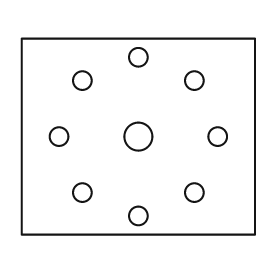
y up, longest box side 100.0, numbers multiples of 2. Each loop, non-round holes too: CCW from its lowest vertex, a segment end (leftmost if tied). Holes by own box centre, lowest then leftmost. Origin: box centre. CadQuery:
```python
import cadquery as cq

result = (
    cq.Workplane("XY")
    .moveTo(-50.0, -42.0)
    .lineTo(50.0, -42.0)
    .lineTo(50.0, 42.0)
    .lineTo(-50.0, 42.0)
    .close()
    .moveTo(0.0, -34.0)
    .circle(4.0)
    .moveTo(-24.0, -24.0)
    .circle(4.0)
    .moveTo(24.0, -24.0)
    .circle(4.0)
    .moveTo(-34.0, 0.0)
    .circle(4.0)
    .moveTo(0.0, 0.0)
    .circle(6.0)
    .moveTo(34.0, 0.0)
    .circle(4.0)
    .moveTo(-24.0, 24.0)
    .circle(4.0)
    .moveTo(24.0, 24.0)
    .circle(4.0)
    .moveTo(0.0, 34.0)
    .circle(4.0)
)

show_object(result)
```